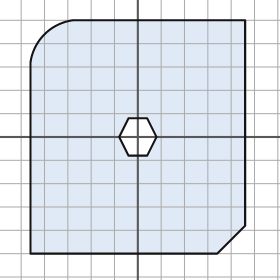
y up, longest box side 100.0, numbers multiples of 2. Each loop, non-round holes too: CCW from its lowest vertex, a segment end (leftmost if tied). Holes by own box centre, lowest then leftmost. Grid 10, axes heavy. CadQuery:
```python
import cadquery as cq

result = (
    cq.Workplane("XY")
    .moveTo(-46.0, -50.0)
    .lineTo(34.0, -50.0)
    .lineTo(46.0, -38.0)
    .lineTo(46.0, 50.0)
    .lineTo(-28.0, 50.0)
    .threePointArc((-40.0, 44.0), (-46.0, 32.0))
    .close()
    .moveTo(-4.0, -8.0)
    .lineTo(4.0, -8.0)
    .lineTo(8.0, 0.0)
    .lineTo(4.0, 8.0)
    .lineTo(-4.0, 8.0)
    .lineTo(-8.0, 0.0)
    .close()
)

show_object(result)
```